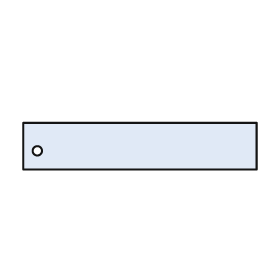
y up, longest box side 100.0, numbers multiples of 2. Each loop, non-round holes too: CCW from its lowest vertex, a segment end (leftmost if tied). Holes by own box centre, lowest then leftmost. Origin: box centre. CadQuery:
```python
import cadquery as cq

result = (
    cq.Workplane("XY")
    .moveTo(-50.0, -10.0)
    .lineTo(50.0, -10.0)
    .lineTo(50.0, 10.0)
    .lineTo(-50.0, 10.0)
    .close()
    .moveTo(-44.0, -2.0)
    .circle(2.0)
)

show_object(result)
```